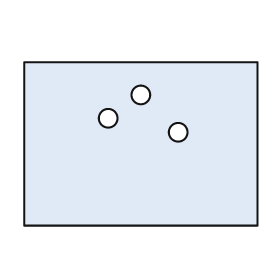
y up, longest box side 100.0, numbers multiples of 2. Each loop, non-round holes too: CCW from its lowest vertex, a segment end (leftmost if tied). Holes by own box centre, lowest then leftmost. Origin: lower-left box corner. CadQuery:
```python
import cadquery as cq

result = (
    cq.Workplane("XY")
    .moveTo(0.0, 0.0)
    .lineTo(100.0, 0.0)
    .lineTo(100.0, 70.0)
    .lineTo(0.0, 70.0)
    .close()
    .moveTo(66.0, 40.0)
    .circle(4.0)
    .moveTo(36.0, 46.0)
    .circle(4.0)
    .moveTo(50.0, 56.0)
    .circle(4.0)
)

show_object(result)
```